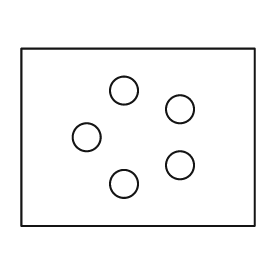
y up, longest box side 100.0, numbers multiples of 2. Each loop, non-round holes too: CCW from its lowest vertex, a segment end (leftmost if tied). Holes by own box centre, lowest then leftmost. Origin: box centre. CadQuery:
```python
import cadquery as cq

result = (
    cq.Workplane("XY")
    .moveTo(-50.0, -38.0)
    .lineTo(50.0, -38.0)
    .lineTo(50.0, 38.0)
    .lineTo(-50.0, 38.0)
    .close()
    .moveTo(-6.0, -20.0)
    .circle(6.0)
    .moveTo(18.0, -12.0)
    .circle(6.0)
    .moveTo(-22.0, 0.0)
    .circle(6.0)
    .moveTo(18.0, 12.0)
    .circle(6.0)
    .moveTo(-6.0, 20.0)
    .circle(6.0)
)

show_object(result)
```